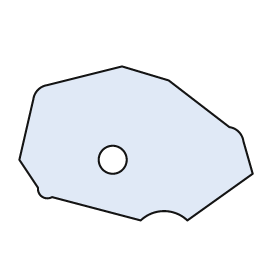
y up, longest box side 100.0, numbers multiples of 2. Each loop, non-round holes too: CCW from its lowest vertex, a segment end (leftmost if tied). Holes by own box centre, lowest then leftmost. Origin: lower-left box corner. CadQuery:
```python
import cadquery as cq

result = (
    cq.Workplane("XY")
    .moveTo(52.0, 0.0)
    .threePointArc((62.0, 4.0), (72.0, 0.0))
    .lineTo(100.0, 20.0)
    .lineTo(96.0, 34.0)
    .threePointArc((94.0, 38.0), (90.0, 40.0))
    .lineTo(64.0, 60.0)
    .lineTo(44.0, 66.0)
    .lineTo(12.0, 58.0)
    .threePointArc((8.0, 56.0), (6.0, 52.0))
    .lineTo(0.0, 26.0)
    .lineTo(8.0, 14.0)
    .threePointArc((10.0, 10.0), (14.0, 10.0))
    .close()
    .moveTo(40.0, 26.0)
    .circle(6.0)
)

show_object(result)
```